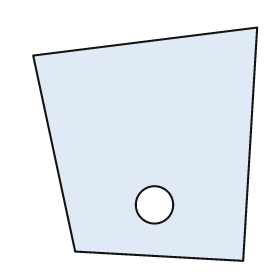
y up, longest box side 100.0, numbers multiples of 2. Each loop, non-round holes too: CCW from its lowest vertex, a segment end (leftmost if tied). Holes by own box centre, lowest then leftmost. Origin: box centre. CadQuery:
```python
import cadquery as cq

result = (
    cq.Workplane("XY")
    .moveTo(42.0, -50.0)
    .lineTo(48.0, 50.0)
    .lineTo(-48.0, 38.0)
    .lineTo(-30.0, -46.0)
    .close()
    .moveTo(4.0, -26.0)
    .circle(8.0)
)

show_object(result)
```